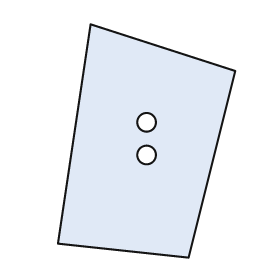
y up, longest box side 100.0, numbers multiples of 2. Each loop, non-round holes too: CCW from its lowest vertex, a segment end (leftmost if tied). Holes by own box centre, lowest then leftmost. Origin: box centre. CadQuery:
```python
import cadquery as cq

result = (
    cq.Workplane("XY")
    .moveTo(18.0, -50.0)
    .lineTo(38.0, 30.0)
    .lineTo(-24.0, 50.0)
    .lineTo(-38.0, -44.0)
    .close()
    .moveTo(0.0, -6.0)
    .circle(4.0)
    .moveTo(0.0, 8.0)
    .circle(4.0)
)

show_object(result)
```